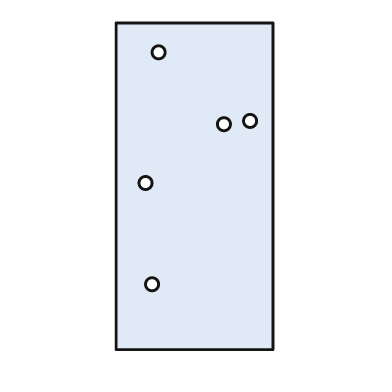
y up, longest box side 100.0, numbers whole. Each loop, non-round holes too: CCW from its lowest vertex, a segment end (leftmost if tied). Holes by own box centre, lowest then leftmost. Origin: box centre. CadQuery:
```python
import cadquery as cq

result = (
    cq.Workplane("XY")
    .moveTo(-24.0, -50.0)
    .lineTo(24.0, -50.0)
    .lineTo(24.0, 50.0)
    .lineTo(-24.0, 50.0)
    .close()
    .moveTo(-13.0, -30.0)
    .circle(2.0)
    .moveTo(-15.0, 1.0)
    .circle(2.0)
    .moveTo(9.0, 19.0)
    .circle(2.0)
    .moveTo(17.0, 20.0)
    .circle(2.0)
    .moveTo(-11.0, 41.0)
    .circle(2.0)
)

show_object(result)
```